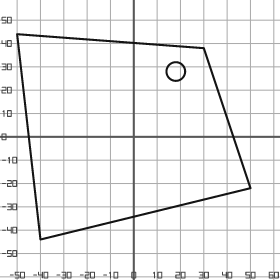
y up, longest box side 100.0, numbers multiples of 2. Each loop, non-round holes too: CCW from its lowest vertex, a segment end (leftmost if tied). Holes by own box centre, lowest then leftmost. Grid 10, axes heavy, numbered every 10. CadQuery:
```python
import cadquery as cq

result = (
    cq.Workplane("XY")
    .moveTo(-40.0, -44.0)
    .lineTo(50.0, -22.0)
    .lineTo(30.0, 38.0)
    .lineTo(-50.0, 44.0)
    .close()
    .moveTo(18.0, 28.0)
    .circle(4.0)
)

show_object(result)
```